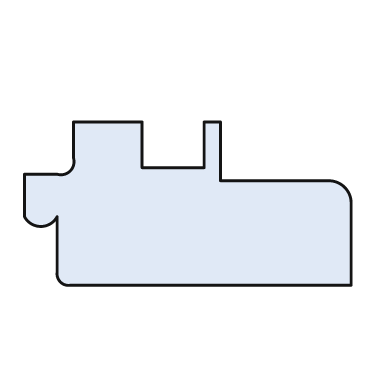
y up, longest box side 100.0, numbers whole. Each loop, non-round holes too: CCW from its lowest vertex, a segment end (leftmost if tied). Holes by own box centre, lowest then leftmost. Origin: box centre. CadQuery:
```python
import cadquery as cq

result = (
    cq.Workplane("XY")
    .moveTo(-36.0, -25.0)
    .lineTo(50.0, -25.0)
    .lineTo(50.0, 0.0)
    .threePointArc((48.0, 5.0), (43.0, 7.0))
    .lineTo(10.0, 7.0)
    .lineTo(10.0, 25.0)
    .lineTo(5.0, 25.0)
    .lineTo(5.0, 11.0)
    .lineTo(-14.0, 11.0)
    .lineTo(-14.0, 25.0)
    .lineTo(-35.0, 25.0)
    .lineTo(-35.0, 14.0)
    .threePointArc((-36.0, 10.0), (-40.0, 9.0))
    .lineTo(-50.0, 9.0)
    .lineTo(-50.0, -4.0)
    .threePointArc((-45.0, -7.0), (-40.0, -4.0))
    .lineTo(-40.0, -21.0)
    .threePointArc((-39.0, -24.0), (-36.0, -25.0))
    .close()
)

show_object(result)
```